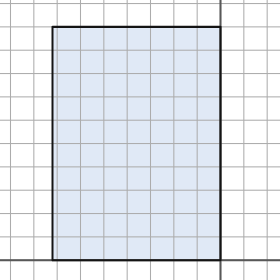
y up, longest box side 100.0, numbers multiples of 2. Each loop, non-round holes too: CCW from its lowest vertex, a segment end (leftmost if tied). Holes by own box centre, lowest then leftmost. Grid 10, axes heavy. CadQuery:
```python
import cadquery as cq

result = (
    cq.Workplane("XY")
    .moveTo(-72.0, 0.0)
    .lineTo(0.0, 0.0)
    .lineTo(0.0, 100.0)
    .lineTo(-72.0, 100.0)
    .close()
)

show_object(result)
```